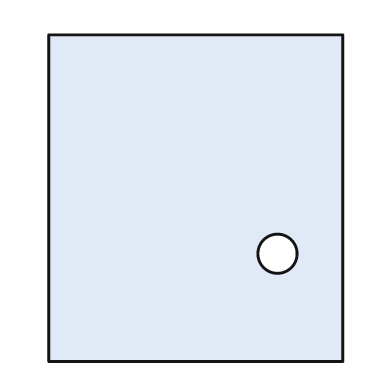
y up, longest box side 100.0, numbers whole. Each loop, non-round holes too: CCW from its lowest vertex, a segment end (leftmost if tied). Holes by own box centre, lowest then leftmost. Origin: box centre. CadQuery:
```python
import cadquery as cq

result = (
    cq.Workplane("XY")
    .moveTo(-45.0, -50.0)
    .lineTo(45.0, -50.0)
    .lineTo(45.0, 50.0)
    .lineTo(-45.0, 50.0)
    .close()
    .moveTo(25.0, -17.0)
    .circle(6.0)
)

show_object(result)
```